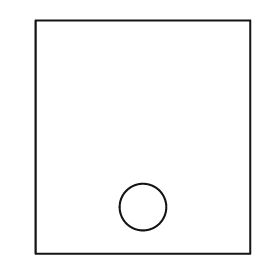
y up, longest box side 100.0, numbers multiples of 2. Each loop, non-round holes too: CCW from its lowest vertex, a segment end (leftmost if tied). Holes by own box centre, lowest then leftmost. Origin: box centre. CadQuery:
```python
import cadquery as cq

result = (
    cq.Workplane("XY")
    .moveTo(-46.0, -50.0)
    .lineTo(46.0, -50.0)
    .lineTo(46.0, 50.0)
    .lineTo(-46.0, 50.0)
    .close()
    .moveTo(0.0, -30.0)
    .circle(10.0)
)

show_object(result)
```